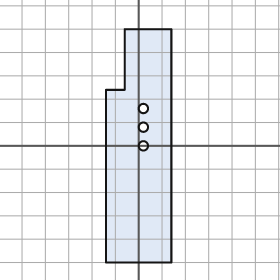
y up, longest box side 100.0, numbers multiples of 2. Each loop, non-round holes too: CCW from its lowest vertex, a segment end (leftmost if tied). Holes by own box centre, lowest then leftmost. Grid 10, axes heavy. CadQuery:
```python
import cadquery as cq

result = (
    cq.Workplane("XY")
    .moveTo(-14.0, -50.0)
    .lineTo(14.0, -50.0)
    .lineTo(14.0, 50.0)
    .lineTo(-6.0, 50.0)
    .lineTo(-6.0, 24.0)
    .lineTo(-14.0, 24.0)
    .close()
    .moveTo(2.0, 0.0)
    .circle(2.0)
    .moveTo(2.0, 8.0)
    .circle(2.0)
    .moveTo(2.0, 16.0)
    .circle(2.0)
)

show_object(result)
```